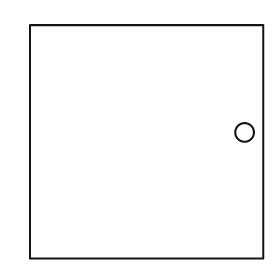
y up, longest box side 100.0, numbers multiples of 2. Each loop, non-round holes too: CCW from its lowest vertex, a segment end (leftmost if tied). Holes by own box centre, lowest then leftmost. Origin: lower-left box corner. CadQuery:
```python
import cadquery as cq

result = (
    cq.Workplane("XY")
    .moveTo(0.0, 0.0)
    .lineTo(100.0, 0.0)
    .lineTo(100.0, 100.0)
    .lineTo(0.0, 100.0)
    .close()
    .moveTo(92.0, 54.0)
    .circle(4.0)
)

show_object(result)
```